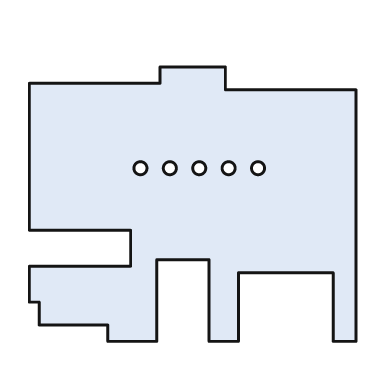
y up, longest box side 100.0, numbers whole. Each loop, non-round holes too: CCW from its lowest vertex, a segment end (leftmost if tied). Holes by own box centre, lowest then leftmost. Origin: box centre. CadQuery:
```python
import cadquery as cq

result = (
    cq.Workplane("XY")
    .moveTo(-26.0, -42.0)
    .lineTo(-11.0, -42.0)
    .lineTo(-11.0, -17.0)
    .lineTo(5.0, -17.0)
    .lineTo(5.0, -42.0)
    .lineTo(14.0, -42.0)
    .lineTo(14.0, -21.0)
    .lineTo(43.0, -21.0)
    .lineTo(43.0, -42.0)
    .lineTo(50.0, -42.0)
    .lineTo(50.0, 35.0)
    .lineTo(10.0, 35.0)
    .lineTo(10.0, 42.0)
    .lineTo(-10.0, 42.0)
    .lineTo(-10.0, 37.0)
    .lineTo(-50.0, 37.0)
    .lineTo(-50.0, -8.0)
    .lineTo(-19.0, -8.0)
    .lineTo(-19.0, -19.0)
    .lineTo(-50.0, -19.0)
    .lineTo(-50.0, -30.0)
    .lineTo(-47.0, -30.0)
    .lineTo(-47.0, -37.0)
    .lineTo(-26.0, -37.0)
    .close()
    .moveTo(-16.0, 11.0)
    .circle(2.0)
    .moveTo(-7.0, 11.0)
    .circle(2.0)
    .moveTo(2.0, 11.0)
    .circle(2.0)
    .moveTo(11.0, 11.0)
    .circle(2.0)
    .moveTo(20.0, 11.0)
    .circle(2.0)
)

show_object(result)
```